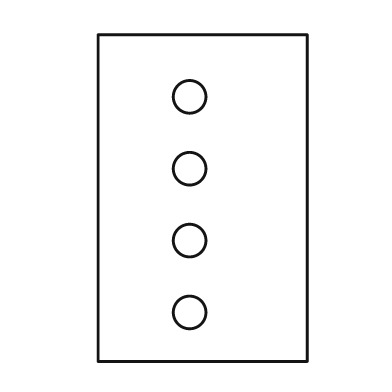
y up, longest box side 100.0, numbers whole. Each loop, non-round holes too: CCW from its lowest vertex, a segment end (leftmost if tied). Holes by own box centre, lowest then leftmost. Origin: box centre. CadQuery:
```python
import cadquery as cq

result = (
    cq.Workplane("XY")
    .moveTo(-32.0, -50.0)
    .lineTo(32.0, -50.0)
    .lineTo(32.0, 50.0)
    .lineTo(-32.0, 50.0)
    .close()
    .moveTo(-4.0, -35.0)
    .circle(5.0)
    .moveTo(-4.0, -13.0)
    .circle(5.0)
    .moveTo(-4.0, 9.0)
    .circle(5.0)
    .moveTo(-4.0, 31.0)
    .circle(5.0)
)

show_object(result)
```